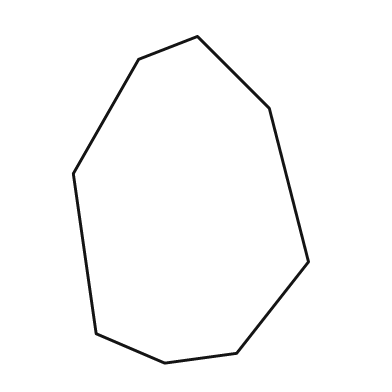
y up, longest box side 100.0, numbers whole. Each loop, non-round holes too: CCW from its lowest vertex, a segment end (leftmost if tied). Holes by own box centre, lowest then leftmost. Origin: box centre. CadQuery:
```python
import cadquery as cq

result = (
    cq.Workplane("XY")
    .moveTo(-8.0, -50.0)
    .lineTo(14.0, -47.0)
    .lineTo(36.0, -19.0)
    .lineTo(24.0, 28.0)
    .lineTo(2.0, 50.0)
    .lineTo(-16.0, 43.0)
    .lineTo(-36.0, 8.0)
    .lineTo(-29.0, -41.0)
    .close()
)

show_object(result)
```